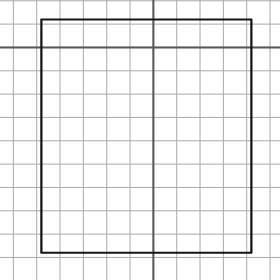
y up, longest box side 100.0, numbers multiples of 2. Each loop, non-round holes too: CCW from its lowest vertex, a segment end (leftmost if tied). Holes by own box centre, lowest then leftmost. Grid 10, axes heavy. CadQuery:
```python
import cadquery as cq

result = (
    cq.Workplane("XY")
    .moveTo(-48.0, -88.0)
    .lineTo(42.0, -88.0)
    .lineTo(42.0, 12.0)
    .lineTo(-48.0, 12.0)
    .close()
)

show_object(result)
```